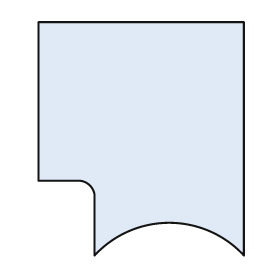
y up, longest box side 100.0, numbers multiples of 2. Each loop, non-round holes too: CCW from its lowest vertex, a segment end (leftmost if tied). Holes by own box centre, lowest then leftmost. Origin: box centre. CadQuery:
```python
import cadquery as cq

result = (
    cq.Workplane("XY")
    .moveTo(-20.0, -50.0)
    .threePointArc((12.0, -36.0), (44.0, -50.0))
    .lineTo(44.0, 50.0)
    .lineTo(-44.0, 50.0)
    .lineTo(-44.0, -18.0)
    .lineTo(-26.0, -18.0)
    .threePointArc((-22.0, -20.0), (-20.0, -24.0))
    .close()
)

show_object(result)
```